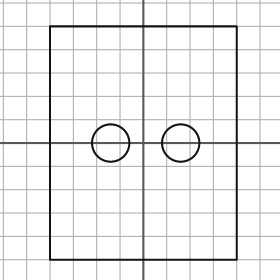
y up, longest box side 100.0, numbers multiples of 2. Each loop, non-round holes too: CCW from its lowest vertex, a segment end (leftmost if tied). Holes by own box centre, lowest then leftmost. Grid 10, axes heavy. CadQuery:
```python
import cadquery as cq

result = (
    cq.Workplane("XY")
    .moveTo(-40.0, -50.0)
    .lineTo(40.0, -50.0)
    .lineTo(40.0, 50.0)
    .lineTo(-40.0, 50.0)
    .close()
    .moveTo(-14.0, 0.0)
    .circle(8.0)
    .moveTo(16.0, 0.0)
    .circle(8.0)
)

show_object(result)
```